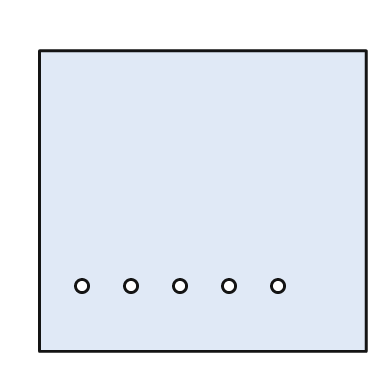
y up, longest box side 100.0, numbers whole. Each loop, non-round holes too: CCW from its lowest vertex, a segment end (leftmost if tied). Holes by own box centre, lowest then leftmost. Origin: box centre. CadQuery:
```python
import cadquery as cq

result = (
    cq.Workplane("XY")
    .moveTo(-50.0, -46.0)
    .lineTo(50.0, -46.0)
    .lineTo(50.0, 46.0)
    .lineTo(-50.0, 46.0)
    .close()
    .moveTo(-37.0, -26.0)
    .circle(2.0)
    .moveTo(-22.0, -26.0)
    .circle(2.0)
    .moveTo(-7.0, -26.0)
    .circle(2.0)
    .moveTo(8.0, -26.0)
    .circle(2.0)
    .moveTo(23.0, -26.0)
    .circle(2.0)
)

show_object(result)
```